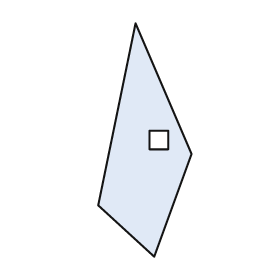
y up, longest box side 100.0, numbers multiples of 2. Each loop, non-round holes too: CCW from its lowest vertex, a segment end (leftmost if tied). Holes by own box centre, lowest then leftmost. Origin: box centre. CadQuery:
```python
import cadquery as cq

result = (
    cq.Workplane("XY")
    .moveTo(4.0, -50.0)
    .lineTo(20.0, -6.0)
    .lineTo(-4.0, 50.0)
    .lineTo(-20.0, -28.0)
    .close()
    .moveTo(2.0, -4.0)
    .lineTo(10.0, -4.0)
    .lineTo(10.0, 4.0)
    .lineTo(2.0, 4.0)
    .close()
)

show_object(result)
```